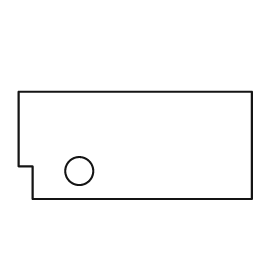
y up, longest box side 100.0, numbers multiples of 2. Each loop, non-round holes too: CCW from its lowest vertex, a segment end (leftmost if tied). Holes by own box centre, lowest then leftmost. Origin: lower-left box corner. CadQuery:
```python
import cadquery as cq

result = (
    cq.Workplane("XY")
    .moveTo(6.0, 0.0)
    .lineTo(100.0, 0.0)
    .lineTo(100.0, 46.0)
    .lineTo(0.0, 46.0)
    .lineTo(0.0, 14.0)
    .lineTo(6.0, 14.0)
    .close()
    .moveTo(26.0, 12.0)
    .circle(6.0)
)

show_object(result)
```